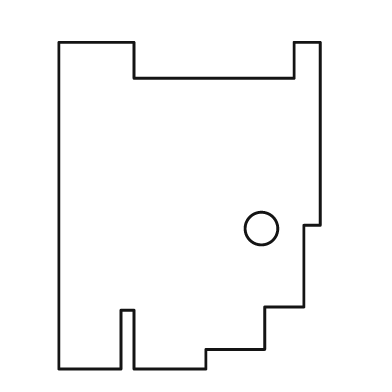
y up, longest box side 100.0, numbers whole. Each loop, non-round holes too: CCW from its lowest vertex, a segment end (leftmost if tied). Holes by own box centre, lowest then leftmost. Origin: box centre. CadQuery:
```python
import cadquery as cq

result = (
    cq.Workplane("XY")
    .moveTo(-40.0, -50.0)
    .lineTo(-21.0, -50.0)
    .lineTo(-21.0, -32.0)
    .lineTo(-17.0, -32.0)
    .lineTo(-17.0, -50.0)
    .lineTo(5.0, -50.0)
    .lineTo(5.0, -44.0)
    .lineTo(23.0, -44.0)
    .lineTo(23.0, -31.0)
    .lineTo(35.0, -31.0)
    .lineTo(35.0, -6.0)
    .lineTo(40.0, -6.0)
    .lineTo(40.0, 50.0)
    .lineTo(32.0, 50.0)
    .lineTo(32.0, 39.0)
    .lineTo(-17.0, 39.0)
    .lineTo(-17.0, 50.0)
    .lineTo(-40.0, 50.0)
    .close()
    .moveTo(22.0, -7.0)
    .circle(5.0)
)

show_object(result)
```